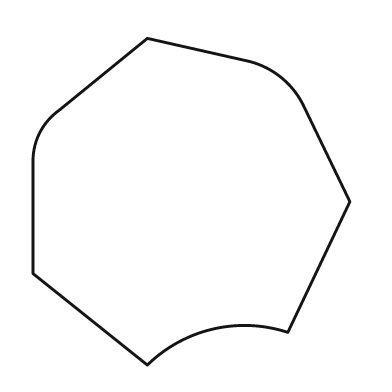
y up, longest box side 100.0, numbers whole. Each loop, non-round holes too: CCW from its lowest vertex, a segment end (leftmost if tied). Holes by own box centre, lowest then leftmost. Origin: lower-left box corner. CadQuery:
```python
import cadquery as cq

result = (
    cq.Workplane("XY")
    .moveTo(35.0, 0.0)
    .threePointArc((55.0, 11.0), (78.0, 10.0))
    .lineTo(97.0, 50.0)
    .lineTo(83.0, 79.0)
    .threePointArc((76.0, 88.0), (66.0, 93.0))
    .lineTo(35.0, 100.0)
    .lineTo(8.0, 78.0)
    .threePointArc((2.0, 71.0), (0.0, 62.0))
    .lineTo(0.0, 28.0)
    .close()
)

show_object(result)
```